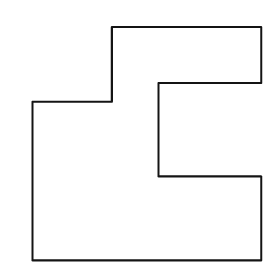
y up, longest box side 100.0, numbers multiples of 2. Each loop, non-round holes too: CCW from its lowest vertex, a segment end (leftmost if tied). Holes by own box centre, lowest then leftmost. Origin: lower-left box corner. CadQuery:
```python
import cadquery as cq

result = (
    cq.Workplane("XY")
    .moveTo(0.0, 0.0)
    .lineTo(98.0, 0.0)
    .lineTo(98.0, 36.0)
    .lineTo(54.0, 36.0)
    .lineTo(54.0, 76.0)
    .lineTo(98.0, 76.0)
    .lineTo(98.0, 100.0)
    .lineTo(34.0, 100.0)
    .lineTo(34.0, 68.0)
    .lineTo(0.0, 68.0)
    .close()
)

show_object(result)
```